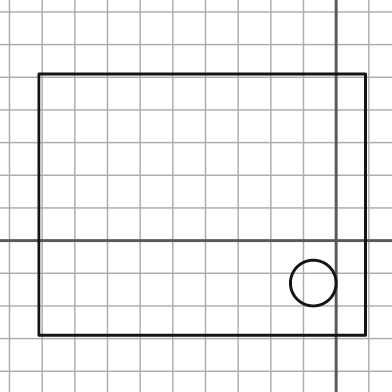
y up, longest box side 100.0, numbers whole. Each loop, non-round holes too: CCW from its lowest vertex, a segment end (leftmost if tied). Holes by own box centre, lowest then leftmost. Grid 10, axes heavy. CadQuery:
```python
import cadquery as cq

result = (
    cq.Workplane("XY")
    .moveTo(-91.0, -29.0)
    .lineTo(9.0, -29.0)
    .lineTo(9.0, 51.0)
    .lineTo(-91.0, 51.0)
    .close()
    .moveTo(-7.0, -13.0)
    .circle(7.0)
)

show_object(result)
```